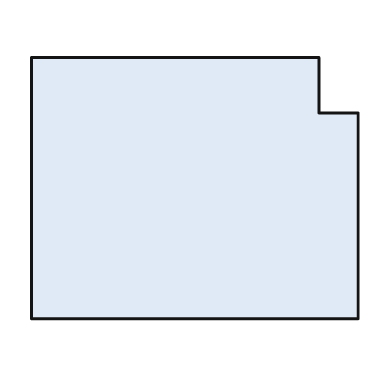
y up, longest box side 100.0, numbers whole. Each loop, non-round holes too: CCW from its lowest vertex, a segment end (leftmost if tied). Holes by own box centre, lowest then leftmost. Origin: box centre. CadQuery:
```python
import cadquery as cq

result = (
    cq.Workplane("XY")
    .moveTo(-50.0, -40.0)
    .lineTo(50.0, -40.0)
    .lineTo(50.0, 23.0)
    .lineTo(38.0, 23.0)
    .lineTo(38.0, 40.0)
    .lineTo(-50.0, 40.0)
    .close()
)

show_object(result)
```